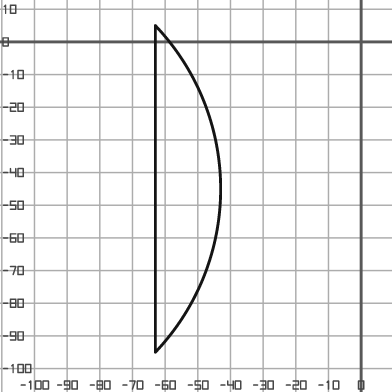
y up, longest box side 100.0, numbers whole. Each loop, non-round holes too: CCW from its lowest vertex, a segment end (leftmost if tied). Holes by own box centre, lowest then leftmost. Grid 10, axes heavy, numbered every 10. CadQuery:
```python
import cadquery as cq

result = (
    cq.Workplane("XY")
    .moveTo(-63.0, -95.0)
    .threePointArc((-43.0, -45.0), (-63.0, 5.0))
    .close()
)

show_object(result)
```